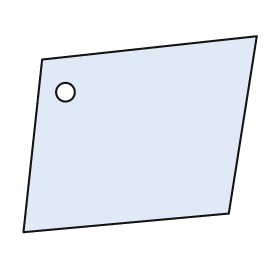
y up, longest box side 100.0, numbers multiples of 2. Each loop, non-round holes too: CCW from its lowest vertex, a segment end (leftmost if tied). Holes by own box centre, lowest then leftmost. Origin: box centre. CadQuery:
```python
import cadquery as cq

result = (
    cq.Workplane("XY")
    .moveTo(-50.0, -42.0)
    .lineTo(38.0, -34.0)
    .lineTo(50.0, 42.0)
    .lineTo(-42.0, 32.0)
    .close()
    .moveTo(-32.0, 18.0)
    .circle(4.0)
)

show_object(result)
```